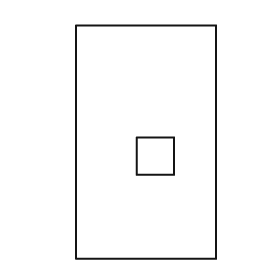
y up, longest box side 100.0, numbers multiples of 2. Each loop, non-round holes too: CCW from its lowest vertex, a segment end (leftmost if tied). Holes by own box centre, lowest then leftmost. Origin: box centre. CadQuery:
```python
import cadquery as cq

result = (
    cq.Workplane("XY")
    .moveTo(-30.0, -50.0)
    .lineTo(30.0, -50.0)
    .lineTo(30.0, 50.0)
    .lineTo(-30.0, 50.0)
    .close()
    .moveTo(-4.0, -14.0)
    .lineTo(12.0, -14.0)
    .lineTo(12.0, 2.0)
    .lineTo(-4.0, 2.0)
    .close()
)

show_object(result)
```